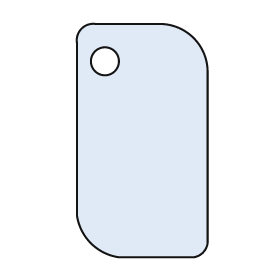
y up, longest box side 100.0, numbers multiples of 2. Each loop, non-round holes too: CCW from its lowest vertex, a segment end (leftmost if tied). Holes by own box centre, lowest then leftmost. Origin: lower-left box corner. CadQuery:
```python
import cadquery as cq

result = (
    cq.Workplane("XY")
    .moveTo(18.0, 0.0)
    .lineTo(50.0, 0.0)
    .threePointArc((54.0, 2.0), (56.0, 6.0))
    .lineTo(56.0, 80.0)
    .threePointArc((50.0, 94.0), (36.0, 100.0))
    .lineTo(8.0, 100.0)
    .threePointArc((2.0, 98.0), (0.0, 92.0))
    .lineTo(0.0, 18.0)
    .threePointArc((6.0, 6.0), (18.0, 0.0))
    .close()
    .moveTo(12.0, 84.0)
    .circle(6.0)
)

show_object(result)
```